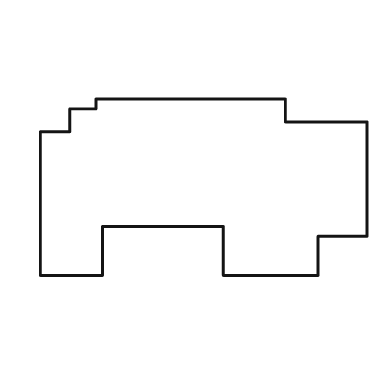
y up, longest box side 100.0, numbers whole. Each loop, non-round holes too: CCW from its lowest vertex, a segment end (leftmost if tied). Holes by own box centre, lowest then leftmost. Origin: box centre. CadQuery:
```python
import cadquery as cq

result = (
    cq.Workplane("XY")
    .moveTo(-50.0, -27.0)
    .lineTo(-31.0, -27.0)
    .lineTo(-31.0, -12.0)
    .lineTo(6.0, -12.0)
    .lineTo(6.0, -27.0)
    .lineTo(35.0, -27.0)
    .lineTo(35.0, -15.0)
    .lineTo(50.0, -15.0)
    .lineTo(50.0, 20.0)
    .lineTo(25.0, 20.0)
    .lineTo(25.0, 27.0)
    .lineTo(-33.0, 27.0)
    .lineTo(-33.0, 24.0)
    .lineTo(-41.0, 24.0)
    .lineTo(-41.0, 17.0)
    .lineTo(-50.0, 17.0)
    .close()
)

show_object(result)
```